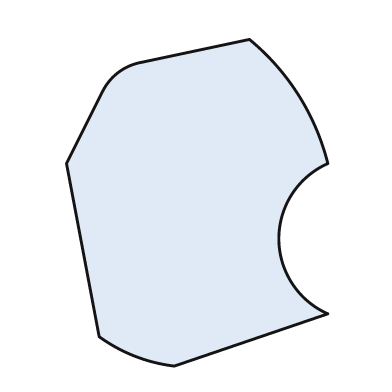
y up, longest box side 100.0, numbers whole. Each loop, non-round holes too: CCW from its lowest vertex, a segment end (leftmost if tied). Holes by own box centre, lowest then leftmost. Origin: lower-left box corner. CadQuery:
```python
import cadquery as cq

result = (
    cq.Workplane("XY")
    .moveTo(33.0, 0.0)
    .lineTo(80.0, 16.0)
    .threePointArc((65.0, 39.0), (80.0, 62.0))
    .threePointArc((71.0, 83.0), (56.0, 100.0))
    .lineTo(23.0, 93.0)
    .threePointArc((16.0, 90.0), (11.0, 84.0))
    .lineTo(0.0, 62.0)
    .lineTo(10.0, 9.0)
    .threePointArc((21.0, 3.0), (33.0, 0.0))
    .close()
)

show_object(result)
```